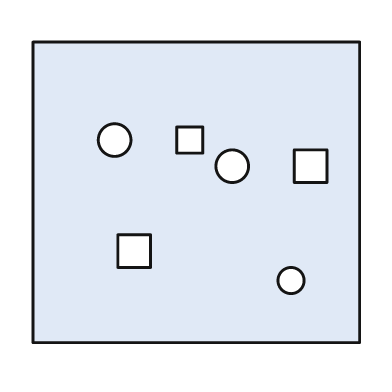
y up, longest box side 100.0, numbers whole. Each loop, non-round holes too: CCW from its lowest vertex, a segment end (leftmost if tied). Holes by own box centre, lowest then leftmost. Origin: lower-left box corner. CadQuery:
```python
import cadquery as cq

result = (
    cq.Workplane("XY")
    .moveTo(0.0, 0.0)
    .lineTo(100.0, 0.0)
    .lineTo(100.0, 92.0)
    .lineTo(0.0, 92.0)
    .close()
    .moveTo(79.0, 19.0)
    .circle(4.0)
    .moveTo(26.0, 23.0)
    .lineTo(36.0, 23.0)
    .lineTo(36.0, 33.0)
    .lineTo(26.0, 33.0)
    .close()
    .moveTo(61.0, 54.0)
    .circle(5.0)
    .moveTo(80.0, 49.0)
    .lineTo(90.0, 49.0)
    .lineTo(90.0, 59.0)
    .lineTo(80.0, 59.0)
    .close()
    .moveTo(25.0, 62.0)
    .circle(5.0)
    .moveTo(44.0, 58.0)
    .lineTo(52.0, 58.0)
    .lineTo(52.0, 66.0)
    .lineTo(44.0, 66.0)
    .close()
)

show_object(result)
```